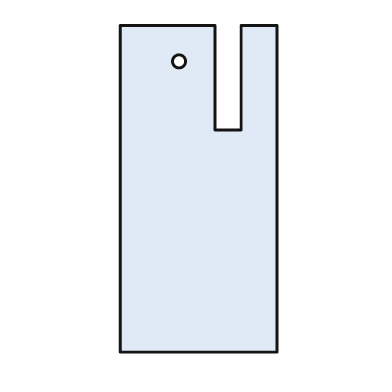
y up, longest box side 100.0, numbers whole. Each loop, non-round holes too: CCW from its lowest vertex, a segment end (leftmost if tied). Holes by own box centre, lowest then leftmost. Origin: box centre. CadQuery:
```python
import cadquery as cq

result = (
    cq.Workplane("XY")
    .moveTo(-24.0, -50.0)
    .lineTo(24.0, -50.0)
    .lineTo(24.0, 50.0)
    .lineTo(13.0, 50.0)
    .lineTo(13.0, 18.0)
    .lineTo(5.0, 18.0)
    .lineTo(5.0, 50.0)
    .lineTo(-24.0, 50.0)
    .close()
    .moveTo(-6.0, 39.0)
    .circle(2.0)
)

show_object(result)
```